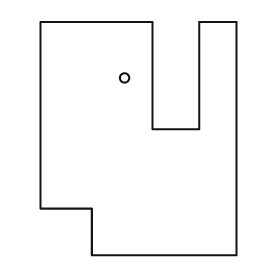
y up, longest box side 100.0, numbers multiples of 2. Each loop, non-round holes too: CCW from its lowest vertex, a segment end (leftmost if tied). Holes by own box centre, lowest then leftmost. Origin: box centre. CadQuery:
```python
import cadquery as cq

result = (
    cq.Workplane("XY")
    .moveTo(-20.0, -50.0)
    .lineTo(42.0, -50.0)
    .lineTo(42.0, 50.0)
    .lineTo(26.0, 50.0)
    .lineTo(26.0, 4.0)
    .lineTo(6.0, 4.0)
    .lineTo(6.0, 50.0)
    .lineTo(-42.0, 50.0)
    .lineTo(-42.0, -30.0)
    .lineTo(-20.0, -30.0)
    .close()
    .moveTo(-6.0, 26.0)
    .circle(2.0)
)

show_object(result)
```